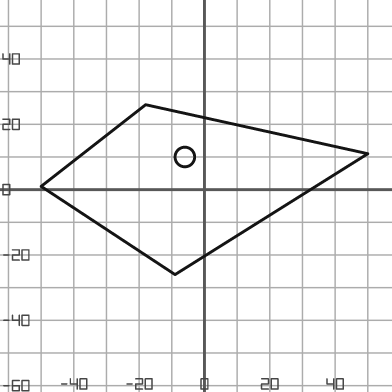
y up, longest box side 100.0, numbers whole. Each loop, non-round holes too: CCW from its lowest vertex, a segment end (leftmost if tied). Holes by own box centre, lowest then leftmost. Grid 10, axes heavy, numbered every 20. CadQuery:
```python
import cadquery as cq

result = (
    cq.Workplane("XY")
    .moveTo(-9.0, -26.0)
    .lineTo(50.0, 11.0)
    .lineTo(-18.0, 26.0)
    .lineTo(-50.0, 1.0)
    .close()
    .moveTo(-6.0, 10.0)
    .circle(3.0)
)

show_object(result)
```